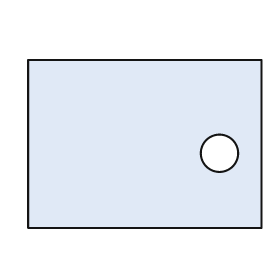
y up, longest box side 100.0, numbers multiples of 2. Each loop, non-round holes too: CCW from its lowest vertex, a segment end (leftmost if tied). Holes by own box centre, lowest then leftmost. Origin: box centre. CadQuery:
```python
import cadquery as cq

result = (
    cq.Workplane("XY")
    .moveTo(-50.0, -36.0)
    .lineTo(50.0, -36.0)
    .lineTo(50.0, 36.0)
    .lineTo(-50.0, 36.0)
    .close()
    .moveTo(32.0, -4.0)
    .circle(8.0)
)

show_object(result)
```